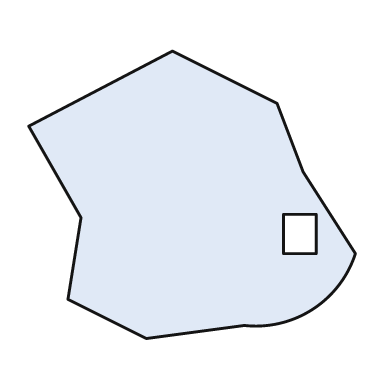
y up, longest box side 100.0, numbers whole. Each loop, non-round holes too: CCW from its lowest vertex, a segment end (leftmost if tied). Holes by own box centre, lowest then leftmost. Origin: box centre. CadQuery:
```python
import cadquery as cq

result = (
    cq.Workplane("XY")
    .moveTo(-14.0, -44.0)
    .lineTo(16.0, -40.0)
    .threePointArc((37.0, -35.0), (50.0, -18.0))
    .lineTo(34.0, 7.0)
    .lineTo(26.0, 28.0)
    .lineTo(-6.0, 44.0)
    .lineTo(-50.0, 21.0)
    .lineTo(-34.0, -7.0)
    .lineTo(-38.0, -32.0)
    .close()
    .moveTo(28.0, -18.0)
    .lineTo(38.0, -18.0)
    .lineTo(38.0, -6.0)
    .lineTo(28.0, -6.0)
    .close()
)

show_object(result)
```